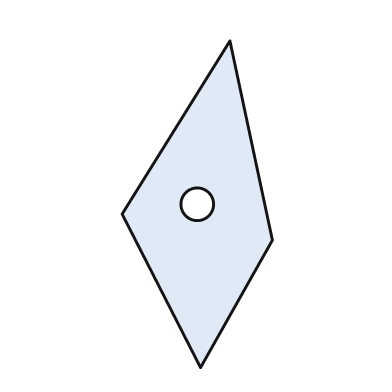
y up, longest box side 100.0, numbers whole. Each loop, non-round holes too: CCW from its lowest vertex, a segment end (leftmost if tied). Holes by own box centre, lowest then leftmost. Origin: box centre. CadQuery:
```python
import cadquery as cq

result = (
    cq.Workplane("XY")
    .moveTo(1.0, -50.0)
    .lineTo(23.0, -11.0)
    .lineTo(10.0, 50.0)
    .lineTo(-23.0, -3.0)
    .close()
    .moveTo(0.0, 0.0)
    .circle(5.0)
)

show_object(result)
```